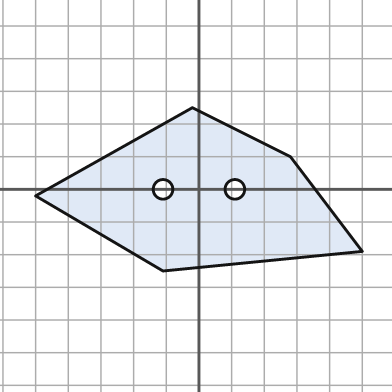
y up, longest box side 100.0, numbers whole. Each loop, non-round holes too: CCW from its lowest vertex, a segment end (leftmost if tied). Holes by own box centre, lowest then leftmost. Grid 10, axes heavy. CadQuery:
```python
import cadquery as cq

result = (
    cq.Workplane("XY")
    .moveTo(-11.0, -25.0)
    .lineTo(50.0, -19.0)
    .lineTo(28.0, 10.0)
    .lineTo(-2.0, 25.0)
    .lineTo(-50.0, -2.0)
    .close()
    .moveTo(-11.0, 0.0)
    .circle(3.0)
    .moveTo(11.0, 0.0)
    .circle(3.0)
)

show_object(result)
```